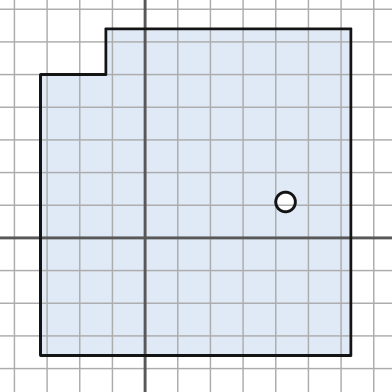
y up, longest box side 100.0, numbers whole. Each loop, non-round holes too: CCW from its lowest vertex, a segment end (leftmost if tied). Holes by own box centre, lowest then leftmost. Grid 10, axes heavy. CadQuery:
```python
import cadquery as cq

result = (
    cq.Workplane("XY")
    .moveTo(-32.0, -36.0)
    .lineTo(63.0, -36.0)
    .lineTo(63.0, 64.0)
    .lineTo(-12.0, 64.0)
    .lineTo(-12.0, 50.0)
    .lineTo(-32.0, 50.0)
    .close()
    .moveTo(43.0, 11.0)
    .circle(3.0)
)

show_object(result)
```